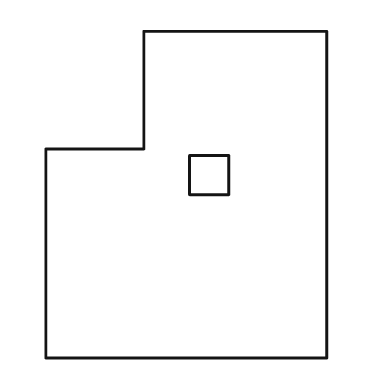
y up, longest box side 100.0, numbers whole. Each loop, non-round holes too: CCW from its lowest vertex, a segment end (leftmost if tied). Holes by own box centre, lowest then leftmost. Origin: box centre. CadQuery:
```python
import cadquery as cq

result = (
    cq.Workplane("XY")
    .moveTo(-43.0, -50.0)
    .lineTo(43.0, -50.0)
    .lineTo(43.0, 50.0)
    .lineTo(-13.0, 50.0)
    .lineTo(-13.0, 14.0)
    .lineTo(-43.0, 14.0)
    .close()
    .moveTo(1.0, 0.0)
    .lineTo(13.0, 0.0)
    .lineTo(13.0, 12.0)
    .lineTo(1.0, 12.0)
    .close()
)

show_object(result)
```